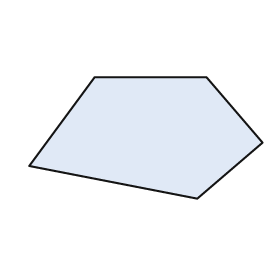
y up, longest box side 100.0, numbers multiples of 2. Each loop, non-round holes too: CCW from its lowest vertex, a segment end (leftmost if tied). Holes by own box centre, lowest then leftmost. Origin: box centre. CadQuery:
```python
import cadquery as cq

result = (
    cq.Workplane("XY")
    .moveTo(22.0, -26.0)
    .lineTo(50.0, -2.0)
    .lineTo(26.0, 26.0)
    .lineTo(-22.0, 26.0)
    .lineTo(-50.0, -12.0)
    .close()
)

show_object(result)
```